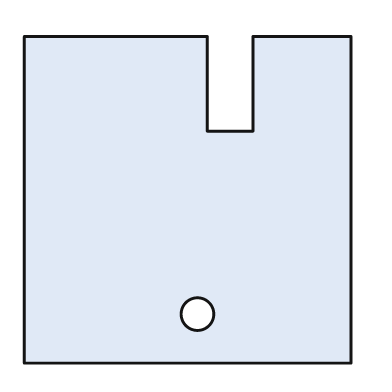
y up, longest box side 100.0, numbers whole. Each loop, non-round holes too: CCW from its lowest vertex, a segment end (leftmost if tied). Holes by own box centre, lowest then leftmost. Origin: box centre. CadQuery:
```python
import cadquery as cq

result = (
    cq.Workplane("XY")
    .moveTo(-50.0, -50.0)
    .lineTo(50.0, -50.0)
    .lineTo(50.0, 50.0)
    .lineTo(20.0, 50.0)
    .lineTo(20.0, 21.0)
    .lineTo(6.0, 21.0)
    .lineTo(6.0, 50.0)
    .lineTo(-50.0, 50.0)
    .close()
    .moveTo(3.0, -35.0)
    .circle(5.0)
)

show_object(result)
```